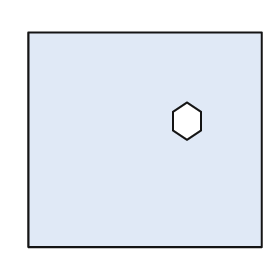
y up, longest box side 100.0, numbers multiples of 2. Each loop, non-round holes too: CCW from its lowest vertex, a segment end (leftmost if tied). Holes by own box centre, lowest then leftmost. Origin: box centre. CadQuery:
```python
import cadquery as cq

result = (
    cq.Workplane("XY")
    .moveTo(-50.0, -46.0)
    .lineTo(50.0, -46.0)
    .lineTo(50.0, 46.0)
    .lineTo(-50.0, 46.0)
    .close()
    .moveTo(18.0, 0.0)
    .lineTo(24.0, 4.0)
    .lineTo(24.0, 12.0)
    .lineTo(18.0, 16.0)
    .lineTo(12.0, 12.0)
    .lineTo(12.0, 4.0)
    .close()
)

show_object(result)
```